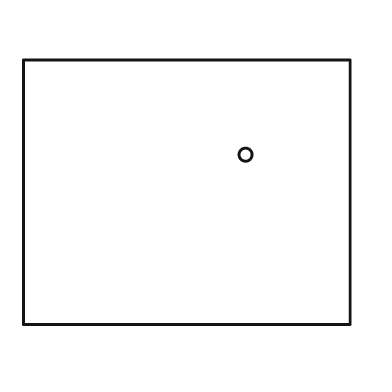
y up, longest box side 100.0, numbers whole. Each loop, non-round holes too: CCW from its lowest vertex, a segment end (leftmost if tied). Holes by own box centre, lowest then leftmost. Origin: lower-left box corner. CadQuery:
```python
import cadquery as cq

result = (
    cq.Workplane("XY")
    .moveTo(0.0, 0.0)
    .lineTo(100.0, 0.0)
    .lineTo(100.0, 81.0)
    .lineTo(0.0, 81.0)
    .close()
    .moveTo(68.0, 52.0)
    .circle(2.0)
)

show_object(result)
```